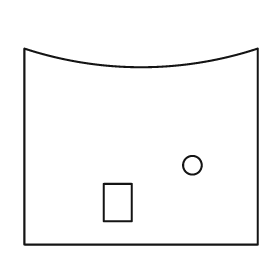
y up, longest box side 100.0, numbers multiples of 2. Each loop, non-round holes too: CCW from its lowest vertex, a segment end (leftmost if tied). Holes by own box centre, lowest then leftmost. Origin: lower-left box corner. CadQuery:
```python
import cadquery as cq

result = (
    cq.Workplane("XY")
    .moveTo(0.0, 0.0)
    .lineTo(100.0, 0.0)
    .lineTo(100.0, 84.0)
    .threePointArc((50.0, 76.0), (0.0, 84.0))
    .close()
    .moveTo(34.0, 10.0)
    .lineTo(46.0, 10.0)
    .lineTo(46.0, 26.0)
    .lineTo(34.0, 26.0)
    .close()
    .moveTo(72.0, 34.0)
    .circle(4.0)
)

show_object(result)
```